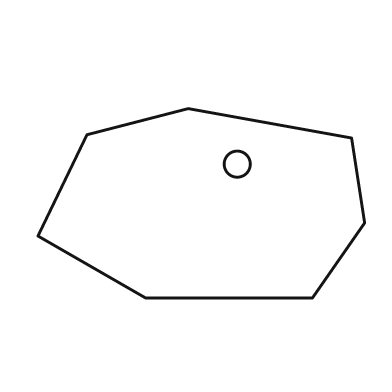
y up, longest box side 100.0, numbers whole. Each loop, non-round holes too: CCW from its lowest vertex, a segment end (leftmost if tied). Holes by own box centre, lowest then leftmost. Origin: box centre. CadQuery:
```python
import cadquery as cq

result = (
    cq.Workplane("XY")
    .moveTo(-17.0, -29.0)
    .lineTo(34.0, -29.0)
    .lineTo(50.0, -6.0)
    .lineTo(46.0, 20.0)
    .lineTo(-4.0, 29.0)
    .lineTo(-35.0, 21.0)
    .lineTo(-50.0, -10.0)
    .close()
    .moveTo(11.0, 12.0)
    .circle(4.0)
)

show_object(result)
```